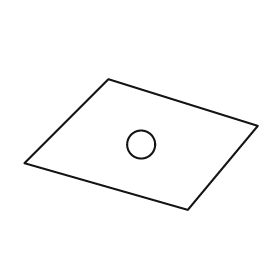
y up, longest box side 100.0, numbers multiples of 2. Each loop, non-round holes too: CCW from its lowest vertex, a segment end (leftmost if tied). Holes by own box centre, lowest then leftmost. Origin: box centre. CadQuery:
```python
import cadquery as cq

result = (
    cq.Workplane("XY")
    .moveTo(20.0, -28.0)
    .lineTo(50.0, 8.0)
    .lineTo(-14.0, 28.0)
    .lineTo(-50.0, -8.0)
    .close()
    .moveTo(0.0, 0.0)
    .circle(6.0)
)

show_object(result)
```